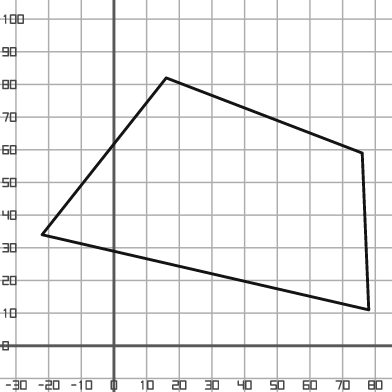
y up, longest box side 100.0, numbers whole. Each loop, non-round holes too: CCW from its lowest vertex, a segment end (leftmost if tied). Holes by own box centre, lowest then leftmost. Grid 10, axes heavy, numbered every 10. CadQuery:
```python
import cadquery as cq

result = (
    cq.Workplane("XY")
    .moveTo(78.0, 11.0)
    .lineTo(76.0, 59.0)
    .lineTo(16.0, 82.0)
    .lineTo(-22.0, 34.0)
    .close()
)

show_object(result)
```